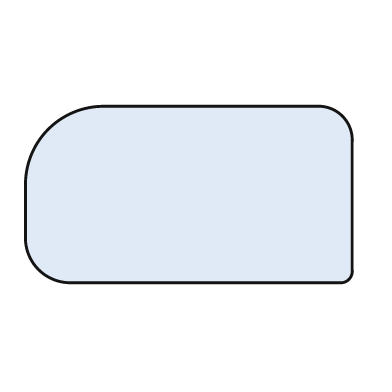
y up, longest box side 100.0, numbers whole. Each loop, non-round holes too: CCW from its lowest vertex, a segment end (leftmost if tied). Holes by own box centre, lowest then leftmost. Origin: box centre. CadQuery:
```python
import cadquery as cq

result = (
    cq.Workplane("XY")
    .moveTo(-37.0, -27.0)
    .lineTo(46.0, -27.0)
    .threePointArc((49.0, -26.0), (50.0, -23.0))
    .lineTo(50.0, 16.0)
    .threePointArc((47.0, 24.0), (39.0, 27.0))
    .lineTo(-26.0, 27.0)
    .threePointArc((-43.0, 20.0), (-50.0, 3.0))
    .lineTo(-50.0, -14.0)
    .threePointArc((-46.0, -23.0), (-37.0, -27.0))
    .close()
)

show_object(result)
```